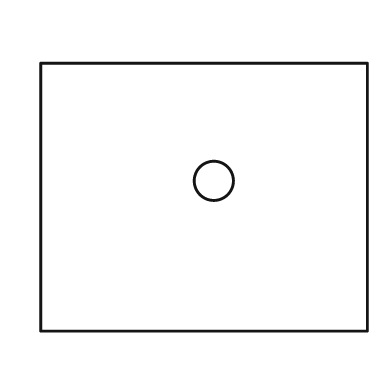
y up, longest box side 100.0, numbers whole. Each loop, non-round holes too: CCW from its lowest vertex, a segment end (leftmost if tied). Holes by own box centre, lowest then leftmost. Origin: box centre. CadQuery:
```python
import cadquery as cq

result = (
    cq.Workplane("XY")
    .moveTo(-50.0, -41.0)
    .lineTo(50.0, -41.0)
    .lineTo(50.0, 41.0)
    .lineTo(-50.0, 41.0)
    .close()
    .moveTo(3.0, 5.0)
    .circle(6.0)
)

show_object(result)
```